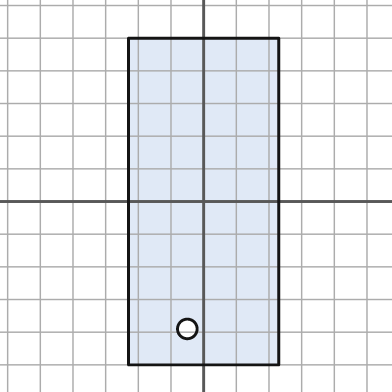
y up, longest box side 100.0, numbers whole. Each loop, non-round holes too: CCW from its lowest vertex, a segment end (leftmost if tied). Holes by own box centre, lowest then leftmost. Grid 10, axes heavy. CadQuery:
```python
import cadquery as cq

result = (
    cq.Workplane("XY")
    .moveTo(-23.0, -50.0)
    .lineTo(23.0, -50.0)
    .lineTo(23.0, 50.0)
    .lineTo(-23.0, 50.0)
    .close()
    .moveTo(-5.0, -39.0)
    .circle(3.0)
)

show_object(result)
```